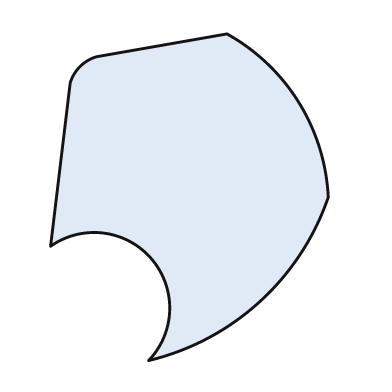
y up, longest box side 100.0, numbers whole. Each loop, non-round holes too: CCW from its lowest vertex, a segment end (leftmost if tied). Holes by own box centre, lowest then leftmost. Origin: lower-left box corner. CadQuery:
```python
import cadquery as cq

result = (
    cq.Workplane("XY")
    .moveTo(30.0, 0.0)
    .threePointArc((64.0, 18.0), (85.0, 50.0))
    .threePointArc((76.0, 79.0), (54.0, 100.0))
    .lineTo(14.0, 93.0)
    .threePointArc((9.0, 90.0), (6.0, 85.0))
    .lineTo(0.0, 35.0)
    .threePointArc((31.0, 31.0), (30.0, 0.0))
    .close()
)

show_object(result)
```